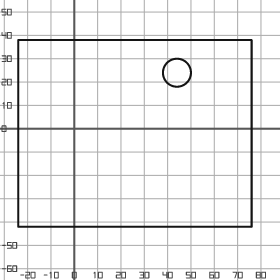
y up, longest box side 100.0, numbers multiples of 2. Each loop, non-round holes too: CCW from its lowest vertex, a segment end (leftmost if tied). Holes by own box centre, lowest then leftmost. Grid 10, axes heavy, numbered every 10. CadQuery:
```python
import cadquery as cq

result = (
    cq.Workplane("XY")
    .moveTo(-24.0, -42.0)
    .lineTo(76.0, -42.0)
    .lineTo(76.0, 38.0)
    .lineTo(-24.0, 38.0)
    .close()
    .moveTo(44.0, 24.0)
    .circle(6.0)
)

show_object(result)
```